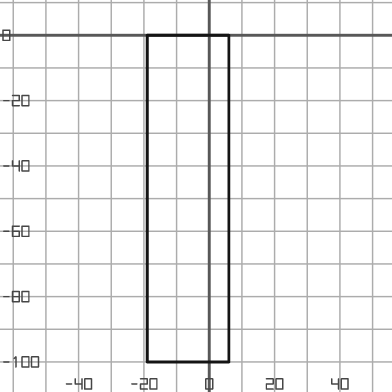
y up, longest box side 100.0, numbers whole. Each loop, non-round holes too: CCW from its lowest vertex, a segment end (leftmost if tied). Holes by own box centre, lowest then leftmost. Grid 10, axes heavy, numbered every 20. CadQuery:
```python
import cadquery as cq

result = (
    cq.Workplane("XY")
    .moveTo(-19.0, -100.0)
    .lineTo(6.0, -100.0)
    .lineTo(6.0, 0.0)
    .lineTo(-19.0, 0.0)
    .close()
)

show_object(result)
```